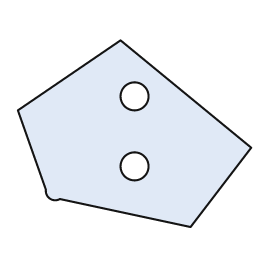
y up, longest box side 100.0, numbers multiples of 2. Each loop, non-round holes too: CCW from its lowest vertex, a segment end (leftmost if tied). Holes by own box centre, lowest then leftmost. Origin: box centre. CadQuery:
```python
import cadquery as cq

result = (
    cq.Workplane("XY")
    .moveTo(24.0, -40.0)
    .lineTo(50.0, -6.0)
    .lineTo(-6.0, 40.0)
    .lineTo(-50.0, 10.0)
    .lineTo(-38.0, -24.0)
    .threePointArc((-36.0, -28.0), (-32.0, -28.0))
    .close()
    .moveTo(0.0, -14.0)
    .circle(6.0)
    .moveTo(0.0, 16.0)
    .circle(6.0)
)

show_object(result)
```